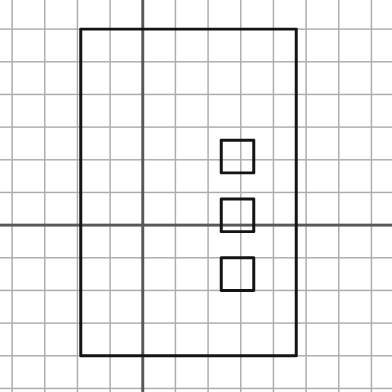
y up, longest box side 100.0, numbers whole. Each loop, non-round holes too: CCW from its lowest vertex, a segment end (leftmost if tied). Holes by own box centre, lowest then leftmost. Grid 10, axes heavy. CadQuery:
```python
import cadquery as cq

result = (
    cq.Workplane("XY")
    .moveTo(-19.0, -40.0)
    .lineTo(47.0, -40.0)
    .lineTo(47.0, 60.0)
    .lineTo(-19.0, 60.0)
    .close()
    .moveTo(24.0, -20.0)
    .lineTo(34.0, -20.0)
    .lineTo(34.0, -10.0)
    .lineTo(24.0, -10.0)
    .close()
    .moveTo(24.0, -2.0)
    .lineTo(34.0, -2.0)
    .lineTo(34.0, 8.0)
    .lineTo(24.0, 8.0)
    .close()
    .moveTo(24.0, 16.0)
    .lineTo(34.0, 16.0)
    .lineTo(34.0, 26.0)
    .lineTo(24.0, 26.0)
    .close()
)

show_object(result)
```